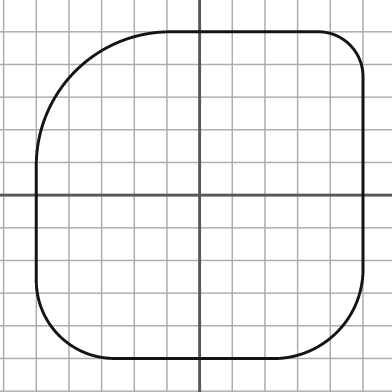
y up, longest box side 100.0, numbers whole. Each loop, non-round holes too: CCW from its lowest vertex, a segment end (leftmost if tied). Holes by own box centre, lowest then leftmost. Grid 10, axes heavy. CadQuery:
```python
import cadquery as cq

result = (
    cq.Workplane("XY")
    .moveTo(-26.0, -50.0)
    .lineTo(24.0, -50.0)
    .threePointArc((42.0, -42.0), (50.0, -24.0))
    .lineTo(50.0, 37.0)
    .threePointArc((46.0, 46.0), (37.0, 50.0))
    .lineTo(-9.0, 50.0)
    .threePointArc((-38.0, 38.0), (-50.0, 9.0))
    .lineTo(-50.0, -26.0)
    .threePointArc((-43.0, -43.0), (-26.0, -50.0))
    .close()
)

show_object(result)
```